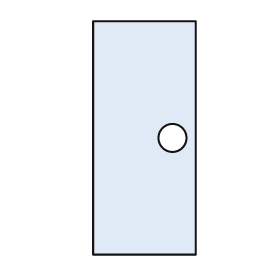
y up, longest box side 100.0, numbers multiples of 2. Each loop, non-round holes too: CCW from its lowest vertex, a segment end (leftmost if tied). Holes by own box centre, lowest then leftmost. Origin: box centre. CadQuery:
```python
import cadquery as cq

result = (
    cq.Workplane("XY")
    .moveTo(-22.0, -50.0)
    .lineTo(22.0, -50.0)
    .lineTo(22.0, 50.0)
    .lineTo(-22.0, 50.0)
    .close()
    .moveTo(12.0, 0.0)
    .circle(6.0)
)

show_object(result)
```